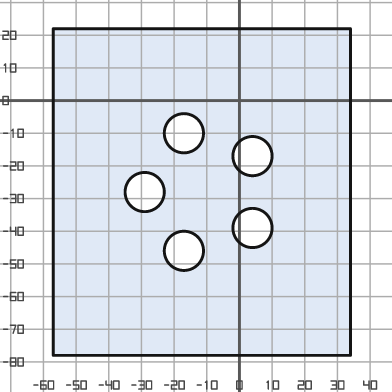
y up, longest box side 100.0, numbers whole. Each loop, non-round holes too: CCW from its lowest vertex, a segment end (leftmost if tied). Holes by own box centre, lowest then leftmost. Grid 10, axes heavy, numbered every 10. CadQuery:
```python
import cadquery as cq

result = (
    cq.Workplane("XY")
    .moveTo(-57.0, -78.0)
    .lineTo(34.0, -78.0)
    .lineTo(34.0, 22.0)
    .lineTo(-57.0, 22.0)
    .close()
    .moveTo(-17.0, -46.0)
    .circle(6.0)
    .moveTo(4.0, -39.0)
    .circle(6.0)
    .moveTo(-29.0, -28.0)
    .circle(6.0)
    .moveTo(4.0, -17.0)
    .circle(6.0)
    .moveTo(-17.0, -10.0)
    .circle(6.0)
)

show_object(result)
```